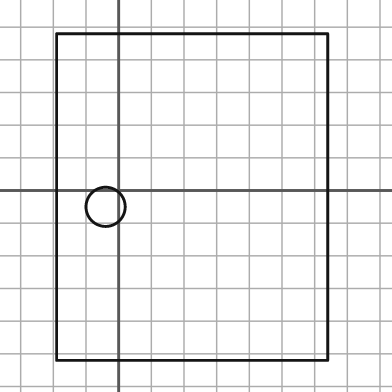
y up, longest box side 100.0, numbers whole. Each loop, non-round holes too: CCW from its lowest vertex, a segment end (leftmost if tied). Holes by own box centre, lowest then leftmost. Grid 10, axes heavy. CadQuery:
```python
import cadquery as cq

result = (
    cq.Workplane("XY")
    .moveTo(-19.0, -52.0)
    .lineTo(64.0, -52.0)
    .lineTo(64.0, 48.0)
    .lineTo(-19.0, 48.0)
    .close()
    .moveTo(-4.0, -5.0)
    .circle(6.0)
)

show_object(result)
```